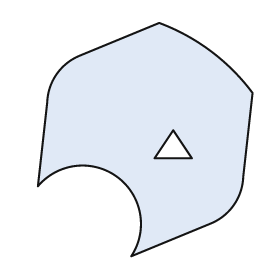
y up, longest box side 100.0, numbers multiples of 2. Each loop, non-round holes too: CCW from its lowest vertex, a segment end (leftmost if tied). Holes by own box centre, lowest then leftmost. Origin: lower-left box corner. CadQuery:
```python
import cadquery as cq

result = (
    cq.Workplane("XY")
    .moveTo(40.0, 0.0)
    .lineTo(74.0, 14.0)
    .threePointArc((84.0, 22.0), (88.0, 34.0))
    .lineTo(92.0, 70.0)
    .threePointArc((74.0, 88.0), (52.0, 100.0))
    .lineTo(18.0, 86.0)
    .threePointArc((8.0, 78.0), (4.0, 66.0))
    .lineTo(0.0, 30.0)
    .threePointArc((34.0, 34.0), (40.0, 0.0))
    .close()
    .moveTo(50.0, 42.0)
    .lineTo(66.0, 42.0)
    .lineTo(58.0, 54.0)
    .close()
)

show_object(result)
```